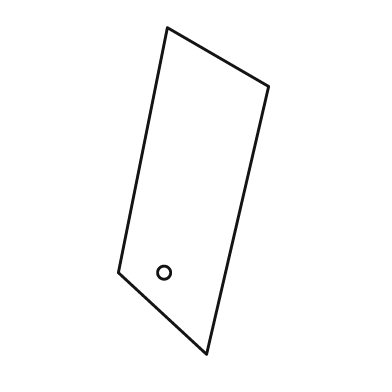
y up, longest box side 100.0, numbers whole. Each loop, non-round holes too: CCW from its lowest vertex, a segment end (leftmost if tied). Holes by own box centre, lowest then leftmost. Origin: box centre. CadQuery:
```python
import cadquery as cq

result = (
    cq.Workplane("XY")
    .moveTo(4.0, -50.0)
    .lineTo(23.0, 32.0)
    .lineTo(-8.0, 50.0)
    .lineTo(-23.0, -25.0)
    .close()
    .moveTo(-9.0, -25.0)
    .circle(2.0)
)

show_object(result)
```